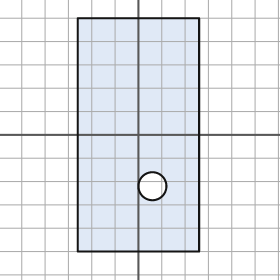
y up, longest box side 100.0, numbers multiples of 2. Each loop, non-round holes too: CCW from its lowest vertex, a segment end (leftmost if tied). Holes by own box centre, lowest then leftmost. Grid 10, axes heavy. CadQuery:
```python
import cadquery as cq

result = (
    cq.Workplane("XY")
    .moveTo(-26.0, -50.0)
    .lineTo(26.0, -50.0)
    .lineTo(26.0, 50.0)
    .lineTo(-26.0, 50.0)
    .close()
    .moveTo(6.0, -22.0)
    .circle(6.0)
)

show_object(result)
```